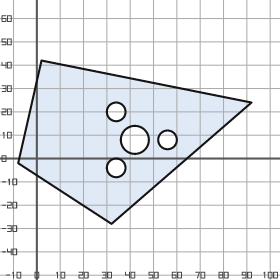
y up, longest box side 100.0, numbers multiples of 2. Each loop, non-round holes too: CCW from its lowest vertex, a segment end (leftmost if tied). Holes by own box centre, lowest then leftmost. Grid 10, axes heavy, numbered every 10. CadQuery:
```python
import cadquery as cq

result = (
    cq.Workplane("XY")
    .moveTo(32.0, -28.0)
    .lineTo(92.0, 24.0)
    .lineTo(2.0, 42.0)
    .lineTo(-8.0, -2.0)
    .close()
    .moveTo(34.0, -4.0)
    .circle(4.0)
    .moveTo(42.0, 8.0)
    .circle(6.0)
    .moveTo(56.0, 8.0)
    .circle(4.0)
    .moveTo(34.0, 20.0)
    .circle(4.0)
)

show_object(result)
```